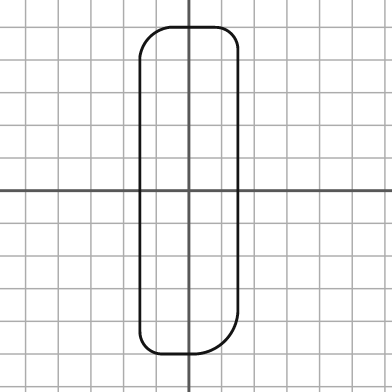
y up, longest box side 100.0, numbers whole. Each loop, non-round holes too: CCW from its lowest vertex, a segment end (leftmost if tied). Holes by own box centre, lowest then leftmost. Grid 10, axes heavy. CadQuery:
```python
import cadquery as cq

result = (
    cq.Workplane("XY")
    .moveTo(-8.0, -50.0)
    .lineTo(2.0, -50.0)
    .threePointArc((11.0, -46.0), (15.0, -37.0))
    .lineTo(15.0, 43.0)
    .threePointArc((13.0, 48.0), (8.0, 50.0))
    .lineTo(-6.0, 50.0)
    .threePointArc((-12.0, 47.0), (-15.0, 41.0))
    .lineTo(-15.0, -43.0)
    .threePointArc((-13.0, -48.0), (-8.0, -50.0))
    .close()
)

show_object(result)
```